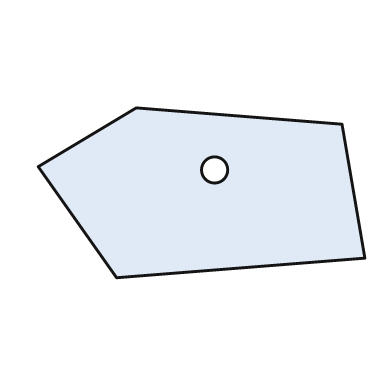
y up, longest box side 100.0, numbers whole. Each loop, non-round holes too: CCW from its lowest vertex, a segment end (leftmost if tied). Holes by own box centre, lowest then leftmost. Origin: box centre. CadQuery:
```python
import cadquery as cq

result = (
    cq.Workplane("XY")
    .moveTo(-26.0, -26.0)
    .lineTo(50.0, -20.0)
    .lineTo(43.0, 21.0)
    .lineTo(-20.0, 26.0)
    .lineTo(-50.0, 8.0)
    .close()
    .moveTo(4.0, 7.0)
    .circle(4.0)
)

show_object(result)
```